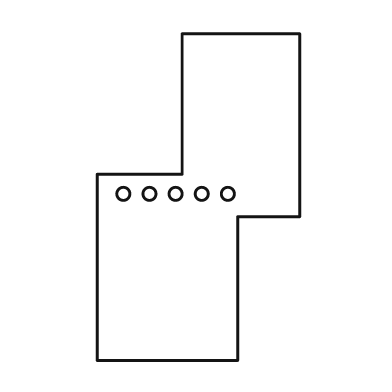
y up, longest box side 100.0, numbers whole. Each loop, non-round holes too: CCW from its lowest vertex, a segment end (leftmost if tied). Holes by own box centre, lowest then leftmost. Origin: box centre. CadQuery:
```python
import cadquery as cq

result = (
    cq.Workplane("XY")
    .moveTo(-31.0, -50.0)
    .lineTo(12.0, -50.0)
    .lineTo(12.0, -6.0)
    .lineTo(31.0, -6.0)
    .lineTo(31.0, 50.0)
    .lineTo(-5.0, 50.0)
    .lineTo(-5.0, 7.0)
    .lineTo(-31.0, 7.0)
    .close()
    .moveTo(-23.0, 1.0)
    .circle(2.0)
    .moveTo(-15.0, 1.0)
    .circle(2.0)
    .moveTo(-7.0, 1.0)
    .circle(2.0)
    .moveTo(1.0, 1.0)
    .circle(2.0)
    .moveTo(9.0, 1.0)
    .circle(2.0)
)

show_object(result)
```